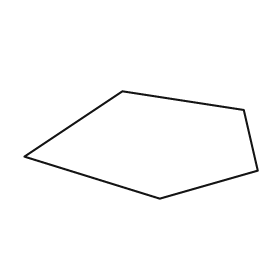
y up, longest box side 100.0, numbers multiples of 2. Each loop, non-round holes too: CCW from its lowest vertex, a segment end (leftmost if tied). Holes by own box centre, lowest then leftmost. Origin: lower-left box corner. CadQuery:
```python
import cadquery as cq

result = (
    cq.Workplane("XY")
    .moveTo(58.0, 0.0)
    .lineTo(100.0, 12.0)
    .lineTo(94.0, 38.0)
    .lineTo(42.0, 46.0)
    .lineTo(0.0, 18.0)
    .close()
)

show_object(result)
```